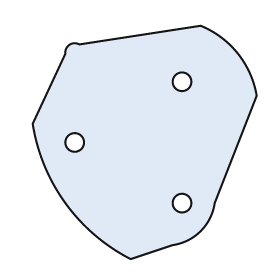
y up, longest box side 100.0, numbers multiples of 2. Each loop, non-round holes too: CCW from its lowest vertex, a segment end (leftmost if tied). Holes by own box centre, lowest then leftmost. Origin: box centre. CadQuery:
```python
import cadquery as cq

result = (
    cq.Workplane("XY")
    .moveTo(-6.0, -50.0)
    .lineTo(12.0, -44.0)
    .threePointArc((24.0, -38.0), (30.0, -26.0))
    .lineTo(48.0, 20.0)
    .threePointArc((40.0, 38.0), (24.0, 50.0))
    .lineTo(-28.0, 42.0)
    .threePointArc((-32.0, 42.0), (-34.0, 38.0))
    .lineTo(-48.0, 8.0)
    .threePointArc((-34.0, -26.0), (-6.0, -50.0))
    .close()
    .moveTo(16.0, -26.0)
    .circle(4.0)
    .moveTo(-30.0, 0.0)
    .circle(4.0)
    .moveTo(16.0, 26.0)
    .circle(4.0)
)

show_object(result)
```